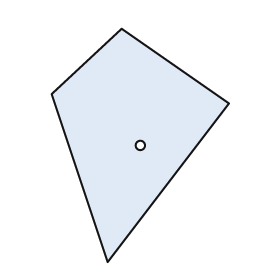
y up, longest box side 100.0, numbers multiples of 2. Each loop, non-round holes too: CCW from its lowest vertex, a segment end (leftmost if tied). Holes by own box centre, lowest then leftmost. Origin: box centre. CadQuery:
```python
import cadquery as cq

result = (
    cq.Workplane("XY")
    .moveTo(-14.0, -50.0)
    .lineTo(38.0, 18.0)
    .lineTo(-8.0, 50.0)
    .lineTo(-38.0, 22.0)
    .close()
    .moveTo(0.0, 0.0)
    .circle(2.0)
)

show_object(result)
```